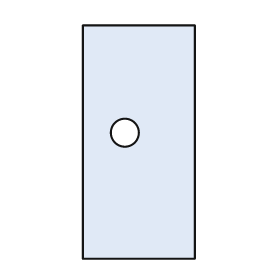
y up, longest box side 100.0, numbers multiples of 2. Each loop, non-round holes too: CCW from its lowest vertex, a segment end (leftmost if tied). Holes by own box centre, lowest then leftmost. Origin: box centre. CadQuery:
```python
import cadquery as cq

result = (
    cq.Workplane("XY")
    .moveTo(-24.0, -50.0)
    .lineTo(24.0, -50.0)
    .lineTo(24.0, 50.0)
    .lineTo(-24.0, 50.0)
    .close()
    .moveTo(-6.0, 4.0)
    .circle(6.0)
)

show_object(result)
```